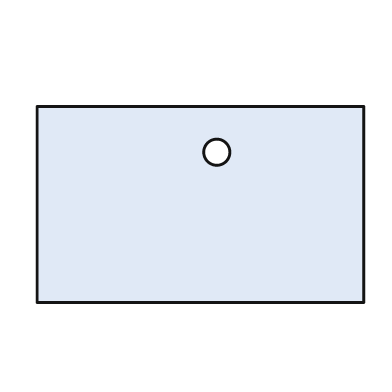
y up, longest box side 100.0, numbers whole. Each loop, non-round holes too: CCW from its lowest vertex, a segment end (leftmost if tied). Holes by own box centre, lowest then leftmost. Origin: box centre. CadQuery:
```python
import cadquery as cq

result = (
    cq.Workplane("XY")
    .moveTo(-50.0, -30.0)
    .lineTo(50.0, -30.0)
    .lineTo(50.0, 30.0)
    .lineTo(-50.0, 30.0)
    .close()
    .moveTo(5.0, 16.0)
    .circle(4.0)
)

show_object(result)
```